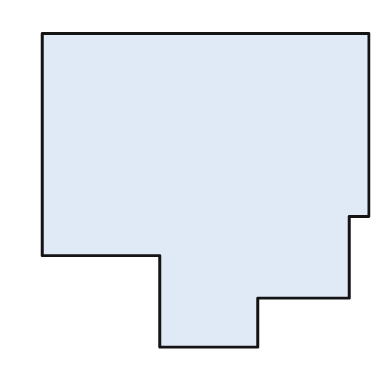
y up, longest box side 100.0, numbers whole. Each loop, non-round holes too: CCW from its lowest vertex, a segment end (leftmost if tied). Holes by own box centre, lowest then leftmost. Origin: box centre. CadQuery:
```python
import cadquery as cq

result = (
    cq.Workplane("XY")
    .moveTo(-14.0, -48.0)
    .lineTo(16.0, -48.0)
    .lineTo(16.0, -33.0)
    .lineTo(44.0, -33.0)
    .lineTo(44.0, -8.0)
    .lineTo(50.0, -8.0)
    .lineTo(50.0, 48.0)
    .lineTo(-50.0, 48.0)
    .lineTo(-50.0, -20.0)
    .lineTo(-14.0, -20.0)
    .close()
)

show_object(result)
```